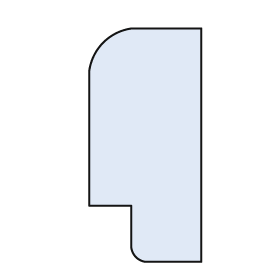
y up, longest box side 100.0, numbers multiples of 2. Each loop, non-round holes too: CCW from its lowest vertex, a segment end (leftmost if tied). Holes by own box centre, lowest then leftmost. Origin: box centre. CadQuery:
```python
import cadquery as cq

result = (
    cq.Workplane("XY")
    .moveTo(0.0, -50.0)
    .lineTo(24.0, -50.0)
    .lineTo(24.0, 50.0)
    .lineTo(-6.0, 50.0)
    .threePointArc((-18.0, 44.0), (-24.0, 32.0))
    .lineTo(-24.0, -26.0)
    .lineTo(-6.0, -26.0)
    .lineTo(-6.0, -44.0)
    .threePointArc((-4.0, -48.0), (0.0, -50.0))
    .close()
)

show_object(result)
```